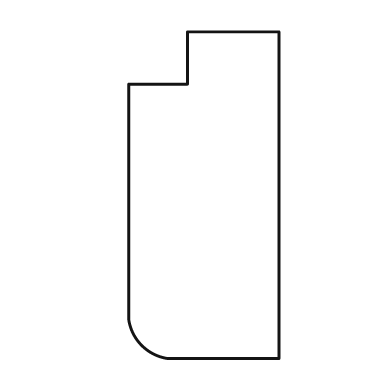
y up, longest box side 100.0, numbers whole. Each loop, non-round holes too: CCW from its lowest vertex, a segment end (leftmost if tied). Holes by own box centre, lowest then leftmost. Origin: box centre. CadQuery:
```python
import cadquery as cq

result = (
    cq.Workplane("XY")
    .moveTo(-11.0, -50.0)
    .lineTo(23.0, -50.0)
    .lineTo(23.0, 50.0)
    .lineTo(-5.0, 50.0)
    .lineTo(-5.0, 34.0)
    .lineTo(-23.0, 34.0)
    .lineTo(-23.0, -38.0)
    .threePointArc((-19.0, -46.0), (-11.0, -50.0))
    .close()
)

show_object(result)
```